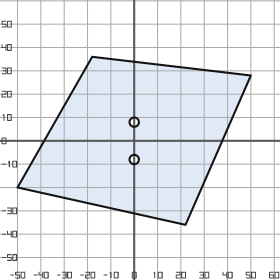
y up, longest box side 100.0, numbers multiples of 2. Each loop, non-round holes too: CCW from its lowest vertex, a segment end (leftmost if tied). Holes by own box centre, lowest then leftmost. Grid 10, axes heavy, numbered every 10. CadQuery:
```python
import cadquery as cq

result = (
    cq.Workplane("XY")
    .moveTo(22.0, -36.0)
    .lineTo(50.0, 28.0)
    .lineTo(-18.0, 36.0)
    .lineTo(-50.0, -20.0)
    .close()
    .moveTo(0.0, -8.0)
    .circle(2.0)
    .moveTo(0.0, 8.0)
    .circle(2.0)
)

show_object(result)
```